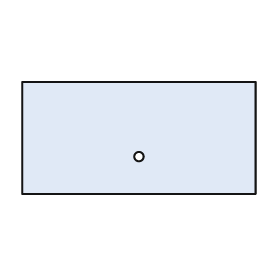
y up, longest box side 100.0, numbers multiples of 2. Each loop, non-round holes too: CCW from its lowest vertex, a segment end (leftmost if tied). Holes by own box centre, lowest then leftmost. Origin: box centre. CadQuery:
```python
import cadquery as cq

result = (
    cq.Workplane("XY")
    .moveTo(-50.0, -24.0)
    .lineTo(50.0, -24.0)
    .lineTo(50.0, 24.0)
    .lineTo(-50.0, 24.0)
    .close()
    .moveTo(0.0, -8.0)
    .circle(2.0)
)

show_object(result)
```